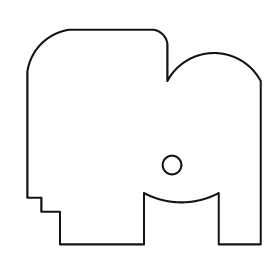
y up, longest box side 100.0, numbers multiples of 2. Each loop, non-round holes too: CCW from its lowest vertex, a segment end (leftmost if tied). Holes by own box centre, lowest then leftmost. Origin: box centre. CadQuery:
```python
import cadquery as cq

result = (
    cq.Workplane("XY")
    .moveTo(-36.0, -46.0)
    .lineTo(0.0, -46.0)
    .lineTo(0.0, -24.0)
    .threePointArc((16.0, -28.0), (32.0, -24.0))
    .lineTo(32.0, -46.0)
    .lineTo(50.0, -46.0)
    .lineTo(50.0, 24.0)
    .threePointArc((30.0, 36.0), (10.0, 24.0))
    .lineTo(10.0, 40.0)
    .threePointArc((8.0, 44.0), (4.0, 46.0))
    .lineTo(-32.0, 46.0)
    .threePointArc((-44.0, 40.0), (-50.0, 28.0))
    .lineTo(-50.0, -26.0)
    .lineTo(-44.0, -26.0)
    .lineTo(-44.0, -32.0)
    .lineTo(-36.0, -32.0)
    .close()
    .moveTo(12.0, -12.0)
    .circle(4.0)
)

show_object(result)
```